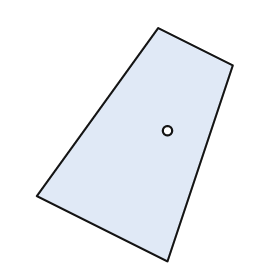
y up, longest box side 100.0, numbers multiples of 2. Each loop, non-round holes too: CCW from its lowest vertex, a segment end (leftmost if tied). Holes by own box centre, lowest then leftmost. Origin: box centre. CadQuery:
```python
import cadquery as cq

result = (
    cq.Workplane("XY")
    .moveTo(14.0, -50.0)
    .lineTo(42.0, 34.0)
    .lineTo(10.0, 50.0)
    .lineTo(-42.0, -22.0)
    .close()
    .moveTo(14.0, 6.0)
    .circle(2.0)
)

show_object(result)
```